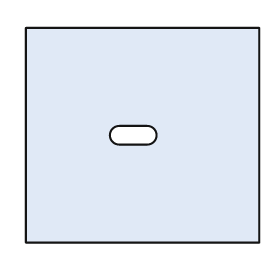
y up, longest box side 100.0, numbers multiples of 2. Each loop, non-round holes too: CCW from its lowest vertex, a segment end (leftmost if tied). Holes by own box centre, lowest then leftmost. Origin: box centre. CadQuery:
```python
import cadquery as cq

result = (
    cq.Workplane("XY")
    .moveTo(-50.0, -46.0)
    .lineTo(50.0, -46.0)
    .lineTo(50.0, 46.0)
    .lineTo(-50.0, 46.0)
    .close()
    .moveTo(-10.0, -4.0)
    .lineTo(2.0, -4.0)
    .threePointArc((6.0, 0.0), (2.0, 4.0))
    .lineTo(-10.0, 4.0)
    .threePointArc((-14.0, 0.0), (-10.0, -4.0))
    .close()
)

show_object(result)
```